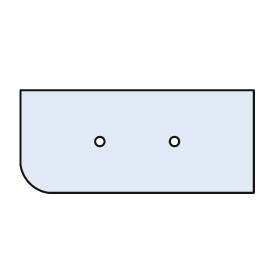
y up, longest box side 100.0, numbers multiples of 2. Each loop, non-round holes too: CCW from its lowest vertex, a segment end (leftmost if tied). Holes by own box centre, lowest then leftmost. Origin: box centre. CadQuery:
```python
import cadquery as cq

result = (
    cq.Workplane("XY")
    .moveTo(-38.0, -22.0)
    .lineTo(50.0, -22.0)
    .lineTo(50.0, 22.0)
    .lineTo(-50.0, 22.0)
    .lineTo(-50.0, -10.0)
    .threePointArc((-46.0, -18.0), (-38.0, -22.0))
    .close()
    .moveTo(-16.0, 0.0)
    .circle(2.0)
    .moveTo(16.0, 0.0)
    .circle(2.0)
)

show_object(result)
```